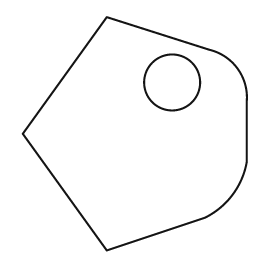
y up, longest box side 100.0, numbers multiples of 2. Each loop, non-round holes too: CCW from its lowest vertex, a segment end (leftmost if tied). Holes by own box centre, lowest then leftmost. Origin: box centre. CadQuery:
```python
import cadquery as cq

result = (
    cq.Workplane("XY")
    .moveTo(-12.0, -50.0)
    .lineTo(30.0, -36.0)
    .threePointArc((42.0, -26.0), (48.0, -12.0))
    .lineTo(48.0, 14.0)
    .threePointArc((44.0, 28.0), (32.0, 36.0))
    .lineTo(-12.0, 50.0)
    .lineTo(-48.0, 0.0)
    .close()
    .moveTo(16.0, 22.0)
    .circle(12.0)
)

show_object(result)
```